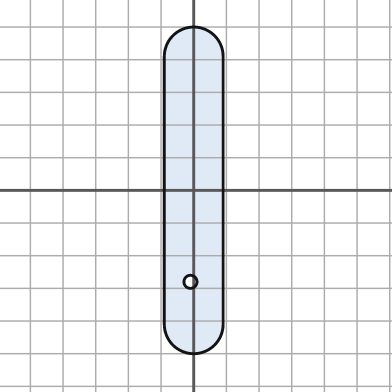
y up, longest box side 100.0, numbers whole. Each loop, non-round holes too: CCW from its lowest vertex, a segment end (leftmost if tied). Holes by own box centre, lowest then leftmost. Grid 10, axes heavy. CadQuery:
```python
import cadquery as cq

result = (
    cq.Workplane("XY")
    .moveTo(-9.0, -41.0)
    .threePointArc((0.0, -50.0), (9.0, -41.0))
    .lineTo(9.0, 41.0)
    .threePointArc((0.0, 50.0), (-9.0, 41.0))
    .close()
    .moveTo(-1.0, -28.0)
    .circle(2.0)
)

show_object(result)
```